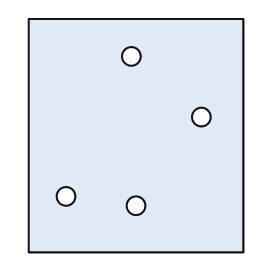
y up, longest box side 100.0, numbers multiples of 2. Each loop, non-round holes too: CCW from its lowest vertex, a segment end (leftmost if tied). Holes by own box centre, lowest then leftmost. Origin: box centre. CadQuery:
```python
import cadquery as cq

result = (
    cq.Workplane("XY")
    .moveTo(-46.0, -50.0)
    .lineTo(46.0, -50.0)
    .lineTo(46.0, 50.0)
    .lineTo(-46.0, 50.0)
    .close()
    .moveTo(0.0, -30.0)
    .circle(4.0)
    .moveTo(-30.0, -26.0)
    .circle(4.0)
    .moveTo(28.0, 8.0)
    .circle(4.0)
    .moveTo(-2.0, 34.0)
    .circle(4.0)
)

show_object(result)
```